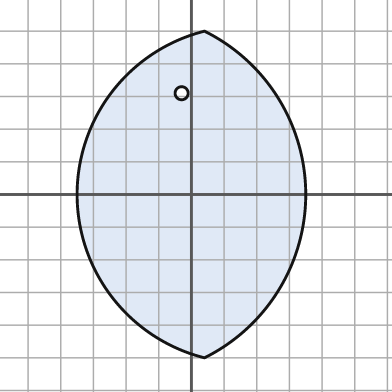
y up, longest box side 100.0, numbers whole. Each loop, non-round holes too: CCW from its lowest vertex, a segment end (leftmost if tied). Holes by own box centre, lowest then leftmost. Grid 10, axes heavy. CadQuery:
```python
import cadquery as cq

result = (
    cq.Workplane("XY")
    .moveTo(4.0, -50.0)
    .threePointArc((35.0, 0.0), (4.0, 50.0))
    .threePointArc((-35.0, 0.0), (4.0, -50.0))
    .close()
    .moveTo(-3.0, 31.0)
    .circle(2.0)
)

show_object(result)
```